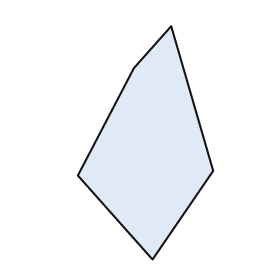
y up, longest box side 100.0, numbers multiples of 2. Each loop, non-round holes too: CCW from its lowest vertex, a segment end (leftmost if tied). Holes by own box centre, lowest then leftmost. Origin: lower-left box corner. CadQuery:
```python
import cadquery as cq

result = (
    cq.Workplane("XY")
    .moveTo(32.0, 0.0)
    .lineTo(58.0, 38.0)
    .lineTo(40.0, 100.0)
    .lineTo(24.0, 82.0)
    .lineTo(0.0, 36.0)
    .close()
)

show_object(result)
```